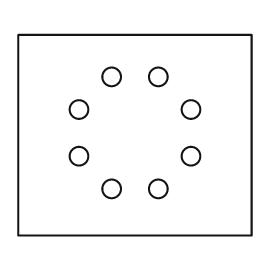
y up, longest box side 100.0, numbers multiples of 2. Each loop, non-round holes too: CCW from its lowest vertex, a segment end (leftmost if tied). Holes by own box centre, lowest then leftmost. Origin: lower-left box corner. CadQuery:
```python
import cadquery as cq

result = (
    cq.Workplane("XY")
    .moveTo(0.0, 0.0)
    .lineTo(100.0, 0.0)
    .lineTo(100.0, 86.0)
    .lineTo(0.0, 86.0)
    .close()
    .moveTo(40.0, 20.0)
    .circle(4.0)
    .moveTo(60.0, 20.0)
    .circle(4.0)
    .moveTo(26.0, 34.0)
    .circle(4.0)
    .moveTo(74.0, 34.0)
    .circle(4.0)
    .moveTo(26.0, 54.0)
    .circle(4.0)
    .moveTo(74.0, 54.0)
    .circle(4.0)
    .moveTo(40.0, 68.0)
    .circle(4.0)
    .moveTo(60.0, 68.0)
    .circle(4.0)
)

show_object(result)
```